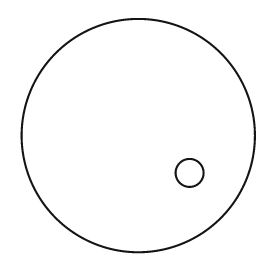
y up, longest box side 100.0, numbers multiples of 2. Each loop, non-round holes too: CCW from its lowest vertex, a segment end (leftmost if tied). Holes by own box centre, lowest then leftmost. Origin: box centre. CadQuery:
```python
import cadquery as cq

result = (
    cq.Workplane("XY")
    .moveTo(0.0, 0.0)
    .circle(50.0)
    .moveTo(22.0, -16.0)
    .circle(6.0)
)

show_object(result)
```